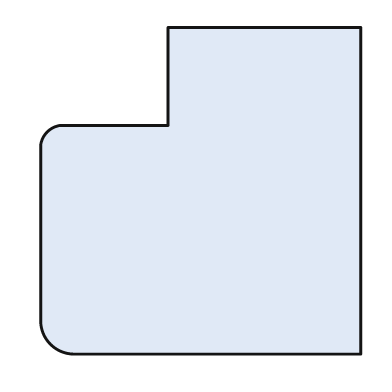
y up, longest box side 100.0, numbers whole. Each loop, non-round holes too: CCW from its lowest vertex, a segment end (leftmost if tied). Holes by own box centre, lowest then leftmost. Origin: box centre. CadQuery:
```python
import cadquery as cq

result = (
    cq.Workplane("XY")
    .moveTo(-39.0, -50.0)
    .lineTo(49.0, -50.0)
    .lineTo(49.0, 50.0)
    .lineTo(-10.0, 50.0)
    .lineTo(-10.0, 20.0)
    .lineTo(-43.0, 20.0)
    .threePointArc((-47.0, 18.0), (-49.0, 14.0))
    .lineTo(-49.0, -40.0)
    .threePointArc((-46.0, -47.0), (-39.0, -50.0))
    .close()
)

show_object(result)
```